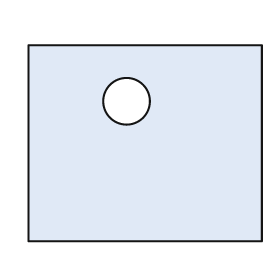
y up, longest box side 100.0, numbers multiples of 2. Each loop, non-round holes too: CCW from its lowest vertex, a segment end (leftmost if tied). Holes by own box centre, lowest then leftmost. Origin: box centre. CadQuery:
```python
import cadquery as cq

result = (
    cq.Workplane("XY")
    .moveTo(-50.0, -42.0)
    .lineTo(50.0, -42.0)
    .lineTo(50.0, 42.0)
    .lineTo(-50.0, 42.0)
    .close()
    .moveTo(-8.0, 18.0)
    .circle(10.0)
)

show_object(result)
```